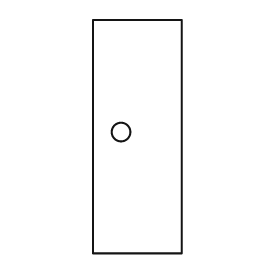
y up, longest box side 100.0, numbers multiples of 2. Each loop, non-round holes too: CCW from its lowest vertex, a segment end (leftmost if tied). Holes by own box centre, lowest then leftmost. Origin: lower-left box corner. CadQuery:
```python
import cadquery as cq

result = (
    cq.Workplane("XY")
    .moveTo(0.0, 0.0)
    .lineTo(38.0, 0.0)
    .lineTo(38.0, 100.0)
    .lineTo(0.0, 100.0)
    .close()
    .moveTo(12.0, 52.0)
    .circle(4.0)
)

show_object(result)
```